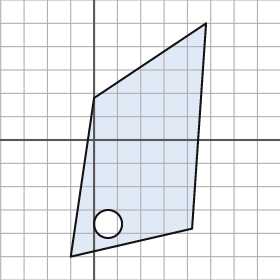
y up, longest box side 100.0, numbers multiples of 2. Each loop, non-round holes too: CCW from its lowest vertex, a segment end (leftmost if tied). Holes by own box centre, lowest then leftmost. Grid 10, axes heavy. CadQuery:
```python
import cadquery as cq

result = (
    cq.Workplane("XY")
    .moveTo(-10.0, -50.0)
    .lineTo(42.0, -38.0)
    .lineTo(48.0, 50.0)
    .lineTo(0.0, 18.0)
    .close()
    .moveTo(6.0, -36.0)
    .circle(6.0)
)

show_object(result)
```